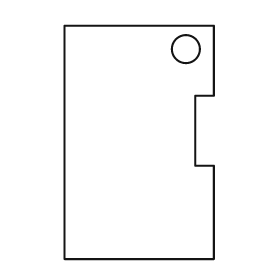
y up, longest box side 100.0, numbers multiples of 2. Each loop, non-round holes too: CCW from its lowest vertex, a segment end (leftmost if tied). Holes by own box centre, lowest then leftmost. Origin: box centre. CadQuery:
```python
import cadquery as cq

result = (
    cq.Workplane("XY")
    .moveTo(-32.0, -50.0)
    .lineTo(32.0, -50.0)
    .lineTo(32.0, -10.0)
    .lineTo(24.0, -10.0)
    .lineTo(24.0, 20.0)
    .lineTo(32.0, 20.0)
    .lineTo(32.0, 50.0)
    .lineTo(-32.0, 50.0)
    .close()
    .moveTo(20.0, 40.0)
    .circle(6.0)
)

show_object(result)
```